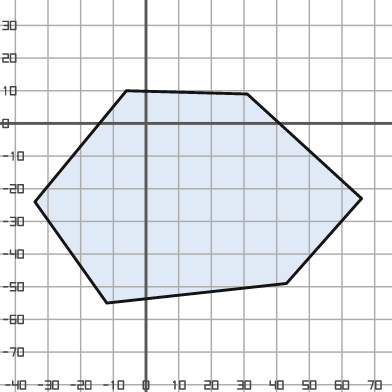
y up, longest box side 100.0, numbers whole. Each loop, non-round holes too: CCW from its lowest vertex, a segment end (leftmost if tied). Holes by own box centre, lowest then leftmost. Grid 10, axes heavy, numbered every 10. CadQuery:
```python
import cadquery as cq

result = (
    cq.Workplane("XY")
    .moveTo(-12.0, -55.0)
    .lineTo(43.0, -49.0)
    .lineTo(66.0, -23.0)
    .lineTo(31.0, 9.0)
    .lineTo(-6.0, 10.0)
    .lineTo(-34.0, -24.0)
    .close()
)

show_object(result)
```